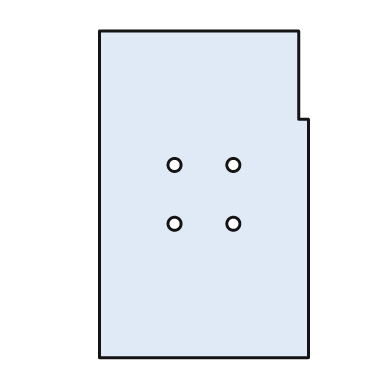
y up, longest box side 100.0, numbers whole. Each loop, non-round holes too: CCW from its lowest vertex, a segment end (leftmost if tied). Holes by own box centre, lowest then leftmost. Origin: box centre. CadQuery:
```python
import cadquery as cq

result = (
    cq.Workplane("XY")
    .moveTo(-32.0, -50.0)
    .lineTo(32.0, -50.0)
    .lineTo(32.0, 23.0)
    .lineTo(29.0, 23.0)
    .lineTo(29.0, 50.0)
    .lineTo(-32.0, 50.0)
    .close()
    .moveTo(-9.0, -9.0)
    .circle(2.0)
    .moveTo(9.0, -9.0)
    .circle(2.0)
    .moveTo(-9.0, 9.0)
    .circle(2.0)
    .moveTo(9.0, 9.0)
    .circle(2.0)
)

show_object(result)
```